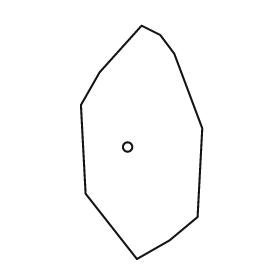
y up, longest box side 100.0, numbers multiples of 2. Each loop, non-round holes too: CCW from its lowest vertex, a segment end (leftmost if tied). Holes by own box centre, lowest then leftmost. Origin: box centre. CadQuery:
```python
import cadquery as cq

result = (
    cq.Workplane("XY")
    .moveTo(-2.0, -50.0)
    .lineTo(12.0, -42.0)
    .lineTo(24.0, -32.0)
    .lineTo(26.0, 6.0)
    .lineTo(14.0, 38.0)
    .lineTo(8.0, 46.0)
    .lineTo(0.0, 50.0)
    .lineTo(-18.0, 30.0)
    .lineTo(-26.0, 16.0)
    .lineTo(-24.0, -22.0)
    .close()
    .moveTo(-6.0, -2.0)
    .circle(2.0)
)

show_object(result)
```